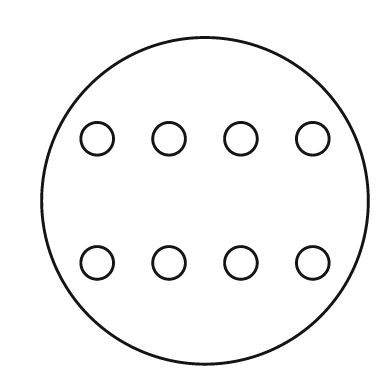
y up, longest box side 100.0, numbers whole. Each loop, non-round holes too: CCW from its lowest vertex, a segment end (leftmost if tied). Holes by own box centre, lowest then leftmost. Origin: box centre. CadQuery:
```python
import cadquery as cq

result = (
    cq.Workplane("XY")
    .moveTo(0.0, 0.0)
    .circle(50.0)
    .moveTo(-33.0, -19.0)
    .circle(5.0)
    .moveTo(-11.0, -19.0)
    .circle(5.0)
    .moveTo(11.0, -19.0)
    .circle(5.0)
    .moveTo(33.0, -19.0)
    .circle(5.0)
    .moveTo(-33.0, 19.0)
    .circle(5.0)
    .moveTo(-11.0, 19.0)
    .circle(5.0)
    .moveTo(11.0, 19.0)
    .circle(5.0)
    .moveTo(33.0, 19.0)
    .circle(5.0)
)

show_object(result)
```